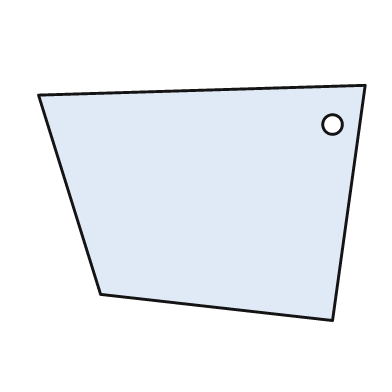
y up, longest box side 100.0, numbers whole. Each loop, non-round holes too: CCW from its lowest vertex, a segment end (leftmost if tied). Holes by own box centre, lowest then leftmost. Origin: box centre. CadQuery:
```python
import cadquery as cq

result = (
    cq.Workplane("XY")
    .moveTo(40.0, -36.0)
    .lineTo(50.0, 36.0)
    .lineTo(-50.0, 33.0)
    .lineTo(-31.0, -28.0)
    .close()
    .moveTo(40.0, 24.0)
    .circle(3.0)
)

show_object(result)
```